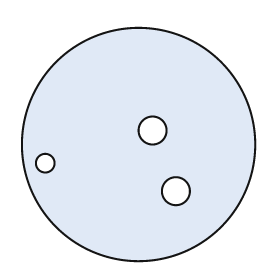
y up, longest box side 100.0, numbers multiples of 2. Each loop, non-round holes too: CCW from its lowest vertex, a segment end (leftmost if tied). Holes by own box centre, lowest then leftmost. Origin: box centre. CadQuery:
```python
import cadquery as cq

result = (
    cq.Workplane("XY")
    .moveTo(0.0, 0.0)
    .circle(50.0)
    .moveTo(16.0, -20.0)
    .circle(6.0)
    .moveTo(-40.0, -8.0)
    .circle(4.0)
    .moveTo(6.0, 6.0)
    .circle(6.0)
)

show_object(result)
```